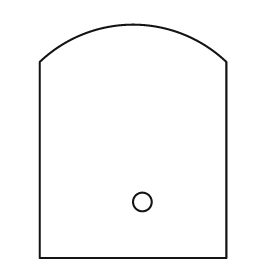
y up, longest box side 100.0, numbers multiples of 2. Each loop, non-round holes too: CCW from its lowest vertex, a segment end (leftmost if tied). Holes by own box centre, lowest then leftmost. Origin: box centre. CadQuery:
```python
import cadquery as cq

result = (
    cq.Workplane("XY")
    .moveTo(-40.0, -50.0)
    .lineTo(40.0, -50.0)
    .lineTo(40.0, 34.0)
    .threePointArc((0.0, 50.0), (-40.0, 34.0))
    .close()
    .moveTo(4.0, -26.0)
    .circle(4.0)
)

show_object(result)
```